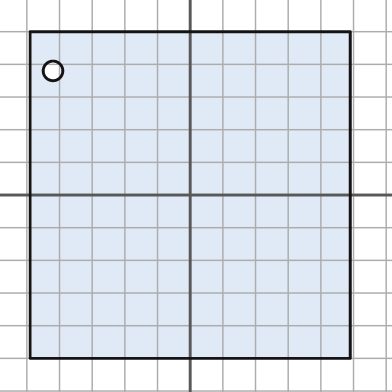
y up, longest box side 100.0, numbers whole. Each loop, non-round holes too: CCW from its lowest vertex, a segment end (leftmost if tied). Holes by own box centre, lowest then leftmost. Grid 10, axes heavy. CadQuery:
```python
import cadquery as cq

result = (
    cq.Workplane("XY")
    .moveTo(-49.0, -50.0)
    .lineTo(49.0, -50.0)
    .lineTo(49.0, 50.0)
    .lineTo(-49.0, 50.0)
    .close()
    .moveTo(-42.0, 38.0)
    .circle(3.0)
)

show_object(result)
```